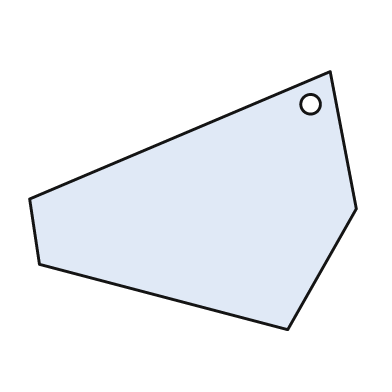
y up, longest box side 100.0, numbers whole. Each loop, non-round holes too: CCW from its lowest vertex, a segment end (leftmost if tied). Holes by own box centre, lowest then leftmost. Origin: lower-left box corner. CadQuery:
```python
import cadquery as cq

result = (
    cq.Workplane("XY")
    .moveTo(79.0, 0.0)
    .lineTo(100.0, 37.0)
    .lineTo(92.0, 79.0)
    .lineTo(0.0, 40.0)
    .lineTo(3.0, 20.0)
    .close()
    .moveTo(86.0, 69.0)
    .circle(3.0)
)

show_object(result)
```